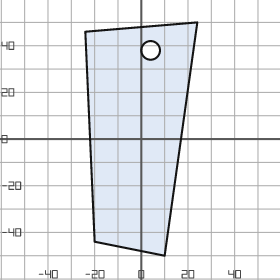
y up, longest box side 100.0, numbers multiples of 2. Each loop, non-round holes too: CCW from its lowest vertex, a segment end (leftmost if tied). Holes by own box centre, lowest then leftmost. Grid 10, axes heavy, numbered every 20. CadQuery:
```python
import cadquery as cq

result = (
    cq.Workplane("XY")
    .moveTo(10.0, -50.0)
    .lineTo(24.0, 50.0)
    .lineTo(-24.0, 46.0)
    .lineTo(-20.0, -44.0)
    .close()
    .moveTo(4.0, 38.0)
    .circle(4.0)
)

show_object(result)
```